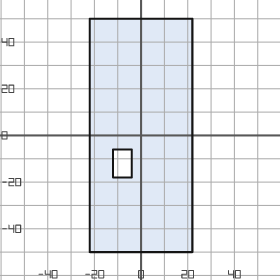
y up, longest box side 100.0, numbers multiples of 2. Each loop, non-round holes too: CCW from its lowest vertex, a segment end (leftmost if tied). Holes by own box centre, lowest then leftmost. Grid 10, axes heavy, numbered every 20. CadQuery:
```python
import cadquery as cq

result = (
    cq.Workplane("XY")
    .moveTo(-22.0, -50.0)
    .lineTo(22.0, -50.0)
    .lineTo(22.0, 50.0)
    .lineTo(-22.0, 50.0)
    .close()
    .moveTo(-12.0, -18.0)
    .lineTo(-4.0, -18.0)
    .lineTo(-4.0, -6.0)
    .lineTo(-12.0, -6.0)
    .close()
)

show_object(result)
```